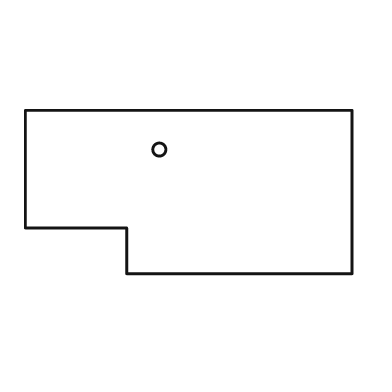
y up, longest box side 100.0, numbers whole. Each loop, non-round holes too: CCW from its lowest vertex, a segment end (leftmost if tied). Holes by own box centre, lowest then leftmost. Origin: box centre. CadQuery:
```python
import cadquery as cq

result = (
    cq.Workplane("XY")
    .moveTo(-19.0, -25.0)
    .lineTo(50.0, -25.0)
    .lineTo(50.0, 25.0)
    .lineTo(-50.0, 25.0)
    .lineTo(-50.0, -11.0)
    .lineTo(-19.0, -11.0)
    .close()
    .moveTo(-9.0, 13.0)
    .circle(2.0)
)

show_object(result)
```